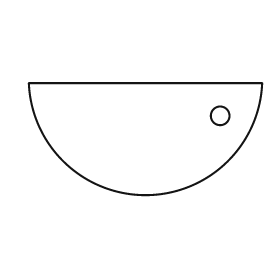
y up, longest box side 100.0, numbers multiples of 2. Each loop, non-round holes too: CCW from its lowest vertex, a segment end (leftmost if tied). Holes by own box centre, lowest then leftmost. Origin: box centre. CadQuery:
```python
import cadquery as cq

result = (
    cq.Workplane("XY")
    .moveTo(-50.0, 24.0)
    .threePointArc((0.0, -24.0), (50.0, 24.0))
    .close()
    .moveTo(32.0, 10.0)
    .circle(4.0)
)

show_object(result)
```